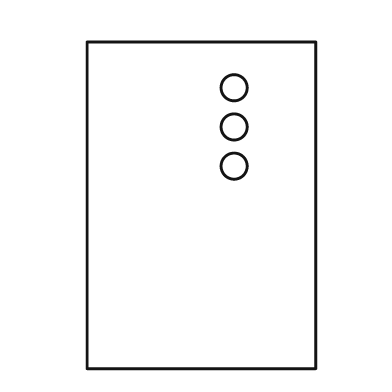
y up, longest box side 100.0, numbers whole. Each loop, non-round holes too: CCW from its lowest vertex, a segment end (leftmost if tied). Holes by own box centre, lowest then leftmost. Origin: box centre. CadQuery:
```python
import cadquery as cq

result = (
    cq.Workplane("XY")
    .moveTo(-35.0, -50.0)
    .lineTo(35.0, -50.0)
    .lineTo(35.0, 50.0)
    .lineTo(-35.0, 50.0)
    .close()
    .moveTo(10.0, 12.0)
    .circle(4.0)
    .moveTo(10.0, 24.0)
    .circle(4.0)
    .moveTo(10.0, 36.0)
    .circle(4.0)
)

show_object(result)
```